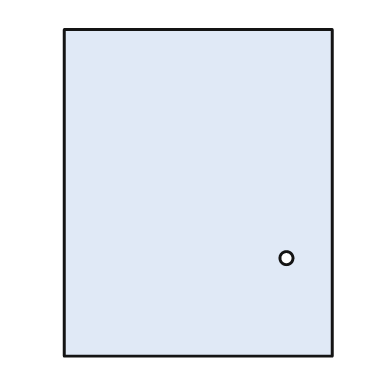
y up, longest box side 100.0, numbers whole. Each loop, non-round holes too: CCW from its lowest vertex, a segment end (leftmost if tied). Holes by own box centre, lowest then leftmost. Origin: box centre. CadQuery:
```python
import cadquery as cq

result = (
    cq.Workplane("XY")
    .moveTo(-41.0, -50.0)
    .lineTo(41.0, -50.0)
    .lineTo(41.0, 50.0)
    .lineTo(-41.0, 50.0)
    .close()
    .moveTo(27.0, -20.0)
    .circle(2.0)
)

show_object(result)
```